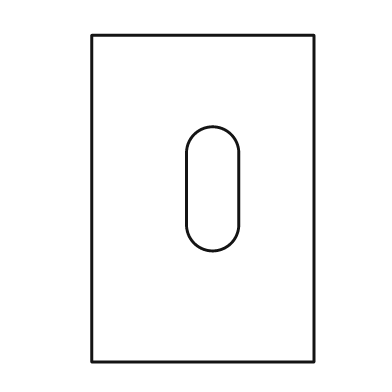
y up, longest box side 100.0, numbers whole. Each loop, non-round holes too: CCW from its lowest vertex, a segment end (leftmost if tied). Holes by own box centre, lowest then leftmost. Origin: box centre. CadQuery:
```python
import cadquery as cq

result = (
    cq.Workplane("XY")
    .moveTo(-34.0, -50.0)
    .lineTo(34.0, -50.0)
    .lineTo(34.0, 50.0)
    .lineTo(-34.0, 50.0)
    .close()
    .moveTo(-5.0, -8.0)
    .threePointArc((3.0, -16.0), (11.0, -8.0))
    .lineTo(11.0, 14.0)
    .threePointArc((3.0, 22.0), (-5.0, 14.0))
    .close()
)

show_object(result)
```